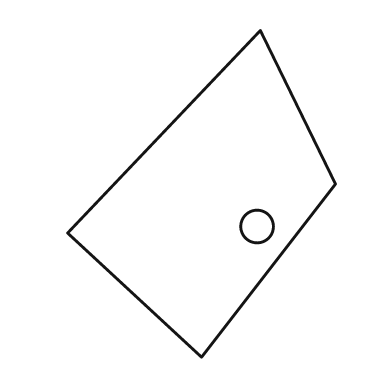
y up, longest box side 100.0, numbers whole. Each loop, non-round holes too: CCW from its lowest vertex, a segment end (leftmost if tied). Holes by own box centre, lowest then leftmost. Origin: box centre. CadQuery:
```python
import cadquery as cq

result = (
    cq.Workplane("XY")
    .moveTo(0.0, -50.0)
    .lineTo(41.0, 3.0)
    .lineTo(18.0, 50.0)
    .lineTo(-41.0, -12.0)
    .close()
    .moveTo(17.0, -10.0)
    .circle(5.0)
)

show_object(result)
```